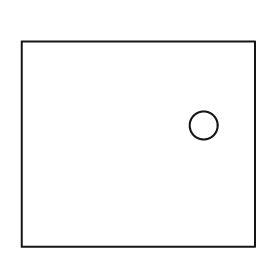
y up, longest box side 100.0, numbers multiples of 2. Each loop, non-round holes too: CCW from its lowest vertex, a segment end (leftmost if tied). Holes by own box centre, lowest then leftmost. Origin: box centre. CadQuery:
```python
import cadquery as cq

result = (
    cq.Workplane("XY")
    .moveTo(-50.0, -44.0)
    .lineTo(50.0, -44.0)
    .lineTo(50.0, 44.0)
    .lineTo(-50.0, 44.0)
    .close()
    .moveTo(28.0, 8.0)
    .circle(6.0)
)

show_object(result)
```